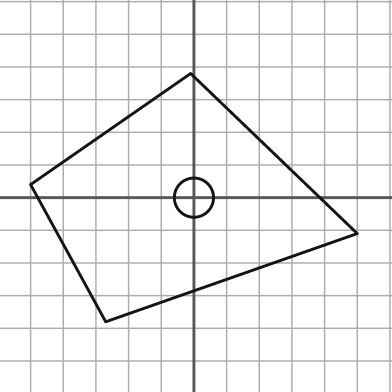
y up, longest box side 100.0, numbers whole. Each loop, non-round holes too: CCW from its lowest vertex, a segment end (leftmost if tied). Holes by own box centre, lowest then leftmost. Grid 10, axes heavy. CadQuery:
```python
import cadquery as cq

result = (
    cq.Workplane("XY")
    .moveTo(-27.0, -38.0)
    .lineTo(50.0, -11.0)
    .lineTo(-1.0, 38.0)
    .lineTo(-50.0, 4.0)
    .close()
    .moveTo(0.0, 0.0)
    .circle(6.0)
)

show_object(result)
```